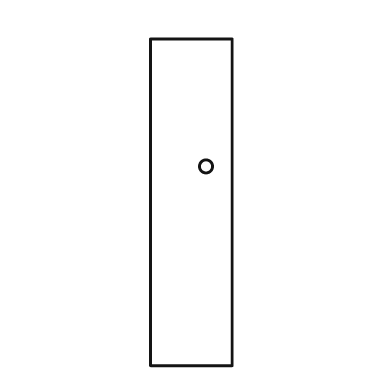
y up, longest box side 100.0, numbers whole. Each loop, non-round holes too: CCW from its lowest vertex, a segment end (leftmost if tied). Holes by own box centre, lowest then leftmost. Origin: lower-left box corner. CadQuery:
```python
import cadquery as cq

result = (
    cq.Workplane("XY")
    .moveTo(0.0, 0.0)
    .lineTo(25.0, 0.0)
    .lineTo(25.0, 100.0)
    .lineTo(0.0, 100.0)
    .close()
    .moveTo(17.0, 61.0)
    .circle(2.0)
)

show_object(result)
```